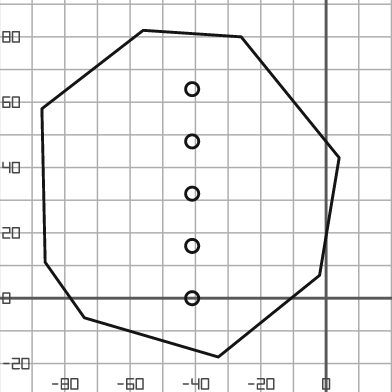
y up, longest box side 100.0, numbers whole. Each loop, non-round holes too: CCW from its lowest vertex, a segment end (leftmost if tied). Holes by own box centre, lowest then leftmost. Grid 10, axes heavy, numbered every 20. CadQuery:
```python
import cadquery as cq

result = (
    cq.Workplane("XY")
    .moveTo(-33.0, -18.0)
    .lineTo(-2.0, 7.0)
    .lineTo(4.0, 43.0)
    .lineTo(-26.0, 80.0)
    .lineTo(-56.0, 82.0)
    .lineTo(-87.0, 58.0)
    .lineTo(-86.0, 11.0)
    .lineTo(-74.0, -6.0)
    .close()
    .moveTo(-41.0, 0.0)
    .circle(2.0)
    .moveTo(-41.0, 16.0)
    .circle(2.0)
    .moveTo(-41.0, 32.0)
    .circle(2.0)
    .moveTo(-41.0, 48.0)
    .circle(2.0)
    .moveTo(-41.0, 64.0)
    .circle(2.0)
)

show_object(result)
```